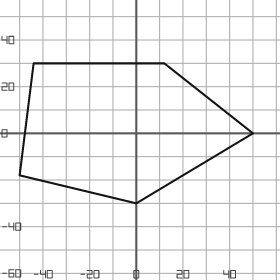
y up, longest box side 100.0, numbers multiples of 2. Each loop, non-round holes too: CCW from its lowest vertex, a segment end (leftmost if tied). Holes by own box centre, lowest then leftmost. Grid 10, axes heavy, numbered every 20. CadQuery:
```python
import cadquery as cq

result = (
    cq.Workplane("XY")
    .moveTo(0.0, -30.0)
    .lineTo(50.0, 0.0)
    .lineTo(12.0, 30.0)
    .lineTo(-44.0, 30.0)
    .lineTo(-50.0, -18.0)
    .close()
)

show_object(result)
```